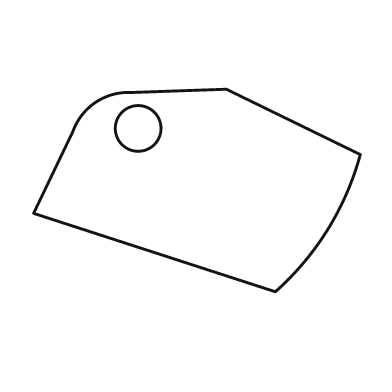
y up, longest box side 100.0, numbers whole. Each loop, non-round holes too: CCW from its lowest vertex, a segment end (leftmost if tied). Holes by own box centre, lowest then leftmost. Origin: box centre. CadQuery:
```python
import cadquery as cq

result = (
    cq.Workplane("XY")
    .moveTo(24.0, -31.0)
    .threePointArc((40.0, -12.0), (50.0, 11.0))
    .lineTo(9.0, 31.0)
    .lineTo(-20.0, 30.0)
    .threePointArc((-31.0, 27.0), (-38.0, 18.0))
    .lineTo(-50.0, -7.0)
    .close()
    .moveTo(-18.0, 19.0)
    .circle(7.0)
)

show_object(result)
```